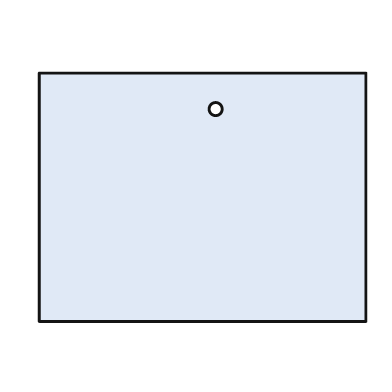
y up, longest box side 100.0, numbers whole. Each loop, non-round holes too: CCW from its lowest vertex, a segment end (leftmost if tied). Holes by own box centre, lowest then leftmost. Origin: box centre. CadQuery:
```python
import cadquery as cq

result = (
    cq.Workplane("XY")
    .moveTo(-50.0, -38.0)
    .lineTo(50.0, -38.0)
    .lineTo(50.0, 38.0)
    .lineTo(-50.0, 38.0)
    .close()
    .moveTo(4.0, 27.0)
    .circle(2.0)
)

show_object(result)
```